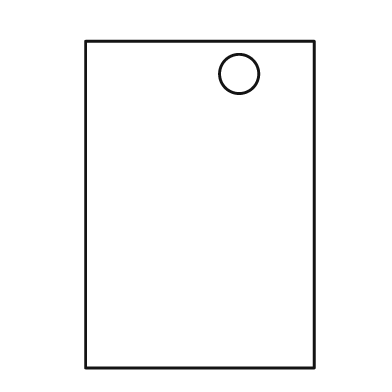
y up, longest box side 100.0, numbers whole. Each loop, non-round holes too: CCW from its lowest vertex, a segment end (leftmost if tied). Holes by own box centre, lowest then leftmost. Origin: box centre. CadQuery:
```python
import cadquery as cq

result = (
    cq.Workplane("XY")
    .moveTo(-35.0, -50.0)
    .lineTo(35.0, -50.0)
    .lineTo(35.0, 50.0)
    .lineTo(-35.0, 50.0)
    .close()
    .moveTo(12.0, 40.0)
    .circle(6.0)
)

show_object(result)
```